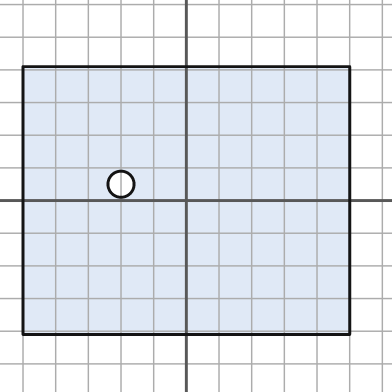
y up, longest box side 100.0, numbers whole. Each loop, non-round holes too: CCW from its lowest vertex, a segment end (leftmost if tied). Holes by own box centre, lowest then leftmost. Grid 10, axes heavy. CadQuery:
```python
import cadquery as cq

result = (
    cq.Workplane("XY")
    .moveTo(-50.0, -41.0)
    .lineTo(50.0, -41.0)
    .lineTo(50.0, 41.0)
    .lineTo(-50.0, 41.0)
    .close()
    .moveTo(-20.0, 5.0)
    .circle(4.0)
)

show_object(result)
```